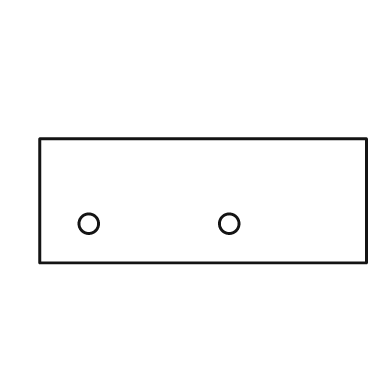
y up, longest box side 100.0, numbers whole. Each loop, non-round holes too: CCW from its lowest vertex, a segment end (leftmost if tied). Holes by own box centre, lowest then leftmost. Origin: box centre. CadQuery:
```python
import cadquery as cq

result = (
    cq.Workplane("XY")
    .moveTo(-50.0, -19.0)
    .lineTo(50.0, -19.0)
    .lineTo(50.0, 19.0)
    .lineTo(-50.0, 19.0)
    .close()
    .moveTo(-35.0, -7.0)
    .circle(3.0)
    .moveTo(8.0, -7.0)
    .circle(3.0)
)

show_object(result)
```